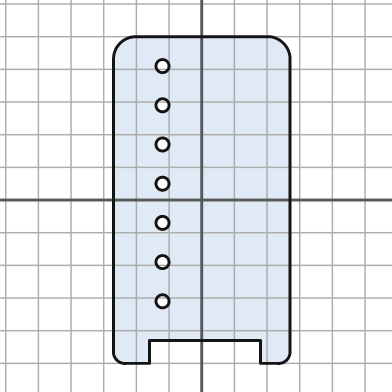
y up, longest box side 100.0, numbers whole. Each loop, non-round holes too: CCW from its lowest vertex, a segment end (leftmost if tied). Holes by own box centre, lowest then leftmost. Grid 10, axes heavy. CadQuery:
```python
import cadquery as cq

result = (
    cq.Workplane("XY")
    .moveTo(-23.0, -50.0)
    .lineTo(-16.0, -50.0)
    .lineTo(-16.0, -43.0)
    .lineTo(18.0, -43.0)
    .lineTo(18.0, -50.0)
    .lineTo(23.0, -50.0)
    .threePointArc((26.0, -49.0), (27.0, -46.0))
    .lineTo(27.0, 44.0)
    .threePointArc((25.0, 48.0), (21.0, 50.0))
    .lineTo(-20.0, 50.0)
    .threePointArc((-25.0, 48.0), (-27.0, 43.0))
    .lineTo(-27.0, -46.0)
    .threePointArc((-26.0, -49.0), (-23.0, -50.0))
    .close()
    .moveTo(-12.0, -31.0)
    .circle(2.0)
    .moveTo(-12.0, -19.0)
    .circle(2.0)
    .moveTo(-12.0, -7.0)
    .circle(2.0)
    .moveTo(-12.0, 5.0)
    .circle(2.0)
    .moveTo(-12.0, 17.0)
    .circle(2.0)
    .moveTo(-12.0, 29.0)
    .circle(2.0)
    .moveTo(-12.0, 41.0)
    .circle(2.0)
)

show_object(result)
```